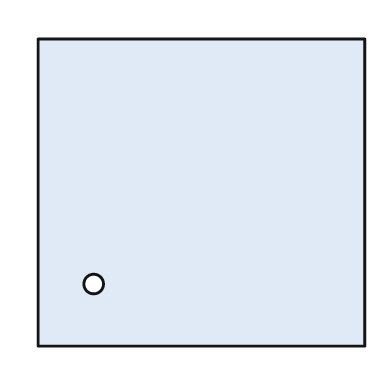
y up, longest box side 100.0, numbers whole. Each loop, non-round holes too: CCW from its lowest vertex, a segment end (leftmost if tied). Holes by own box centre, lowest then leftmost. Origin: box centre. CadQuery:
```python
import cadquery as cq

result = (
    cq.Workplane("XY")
    .moveTo(-50.0, -47.0)
    .lineTo(50.0, -47.0)
    .lineTo(50.0, 47.0)
    .lineTo(-50.0, 47.0)
    .close()
    .moveTo(-33.0, -28.0)
    .circle(3.0)
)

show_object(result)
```